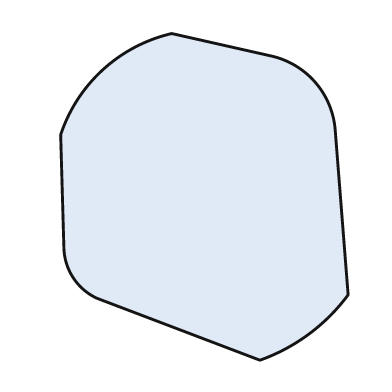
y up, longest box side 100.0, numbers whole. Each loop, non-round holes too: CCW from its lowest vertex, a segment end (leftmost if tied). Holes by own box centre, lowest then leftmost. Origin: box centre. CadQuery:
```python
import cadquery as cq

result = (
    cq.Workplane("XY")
    .moveTo(17.0, -50.0)
    .threePointArc((32.0, -42.0), (44.0, -30.0))
    .lineTo(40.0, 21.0)
    .threePointArc((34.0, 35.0), (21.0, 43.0))
    .lineTo(-10.0, 50.0)
    .threePointArc((-31.0, 39.0), (-44.0, 19.0))
    .lineTo(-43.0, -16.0)
    .threePointArc((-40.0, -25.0), (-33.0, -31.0))
    .close()
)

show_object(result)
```